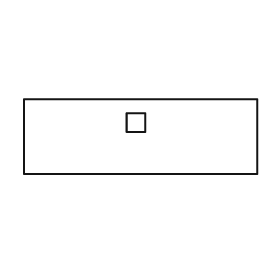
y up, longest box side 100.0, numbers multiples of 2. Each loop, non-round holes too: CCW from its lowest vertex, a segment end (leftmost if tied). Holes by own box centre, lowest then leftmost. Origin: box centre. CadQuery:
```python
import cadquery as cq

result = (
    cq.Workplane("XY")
    .moveTo(-50.0, -16.0)
    .lineTo(50.0, -16.0)
    .lineTo(50.0, 16.0)
    .lineTo(-50.0, 16.0)
    .close()
    .moveTo(-6.0, 2.0)
    .lineTo(2.0, 2.0)
    .lineTo(2.0, 10.0)
    .lineTo(-6.0, 10.0)
    .close()
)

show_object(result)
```